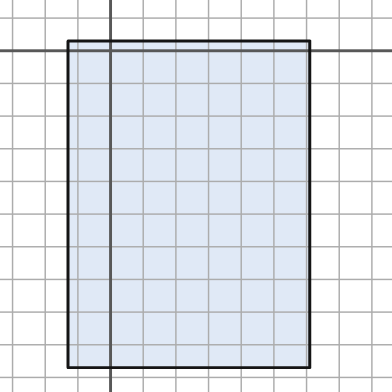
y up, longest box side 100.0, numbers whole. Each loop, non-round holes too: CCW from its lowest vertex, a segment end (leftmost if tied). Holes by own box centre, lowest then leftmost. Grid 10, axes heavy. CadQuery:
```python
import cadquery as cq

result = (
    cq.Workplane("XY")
    .moveTo(-13.0, -97.0)
    .lineTo(61.0, -97.0)
    .lineTo(61.0, 3.0)
    .lineTo(-13.0, 3.0)
    .close()
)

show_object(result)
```